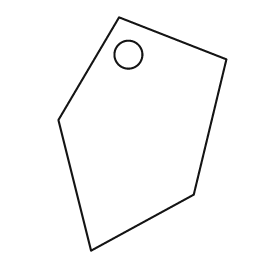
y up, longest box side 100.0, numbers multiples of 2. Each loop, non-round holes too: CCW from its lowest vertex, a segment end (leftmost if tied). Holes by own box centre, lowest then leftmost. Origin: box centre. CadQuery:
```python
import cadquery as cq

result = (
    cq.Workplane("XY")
    .moveTo(-22.0, -50.0)
    .lineTo(22.0, -26.0)
    .lineTo(36.0, 32.0)
    .lineTo(-10.0, 50.0)
    .lineTo(-36.0, 6.0)
    .close()
    .moveTo(-6.0, 34.0)
    .circle(6.0)
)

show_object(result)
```